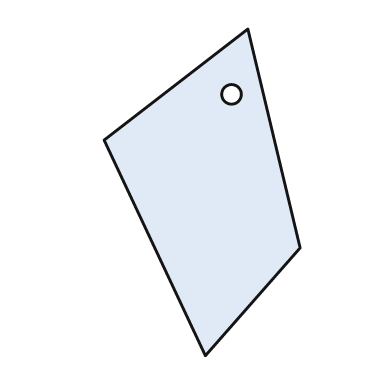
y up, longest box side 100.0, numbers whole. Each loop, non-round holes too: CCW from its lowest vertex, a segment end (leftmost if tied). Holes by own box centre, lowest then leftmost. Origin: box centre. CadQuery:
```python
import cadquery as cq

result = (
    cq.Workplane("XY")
    .moveTo(1.0, -50.0)
    .lineTo(30.0, -17.0)
    .lineTo(14.0, 50.0)
    .lineTo(-30.0, 16.0)
    .close()
    .moveTo(9.0, 30.0)
    .circle(3.0)
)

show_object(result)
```